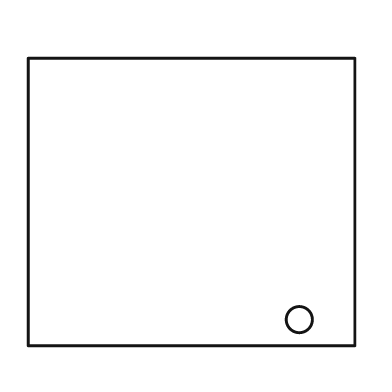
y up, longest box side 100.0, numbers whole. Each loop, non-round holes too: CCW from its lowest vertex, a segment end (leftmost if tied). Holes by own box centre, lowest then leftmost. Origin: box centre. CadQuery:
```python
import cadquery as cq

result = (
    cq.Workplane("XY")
    .moveTo(-50.0, -44.0)
    .lineTo(50.0, -44.0)
    .lineTo(50.0, 44.0)
    .lineTo(-50.0, 44.0)
    .close()
    .moveTo(33.0, -36.0)
    .circle(4.0)
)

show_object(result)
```